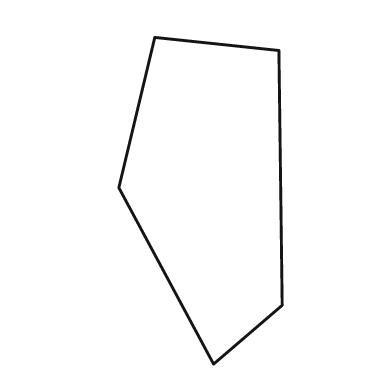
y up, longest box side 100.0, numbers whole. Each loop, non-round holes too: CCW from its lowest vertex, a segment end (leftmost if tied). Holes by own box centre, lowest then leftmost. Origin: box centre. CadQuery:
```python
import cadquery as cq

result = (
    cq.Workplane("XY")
    .moveTo(4.0, -50.0)
    .lineTo(25.0, -32.0)
    .lineTo(24.0, 46.0)
    .lineTo(-14.0, 50.0)
    .lineTo(-25.0, 4.0)
    .close()
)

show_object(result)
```